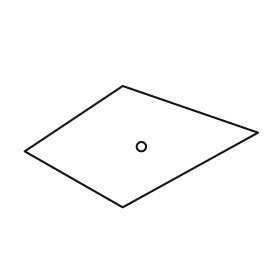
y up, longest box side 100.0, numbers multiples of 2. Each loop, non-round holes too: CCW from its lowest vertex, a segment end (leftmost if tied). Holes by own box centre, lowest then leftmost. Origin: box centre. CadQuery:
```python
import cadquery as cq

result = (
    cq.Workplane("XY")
    .moveTo(-8.0, -26.0)
    .lineTo(50.0, 6.0)
    .lineTo(-8.0, 26.0)
    .lineTo(-50.0, -2.0)
    .close()
    .moveTo(0.0, 0.0)
    .circle(2.0)
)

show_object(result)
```